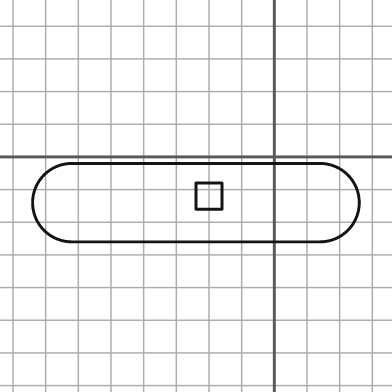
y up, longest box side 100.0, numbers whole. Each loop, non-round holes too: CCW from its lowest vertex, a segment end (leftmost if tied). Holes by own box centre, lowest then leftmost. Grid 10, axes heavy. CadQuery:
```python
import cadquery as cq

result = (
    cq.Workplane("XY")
    .moveTo(-62.0, -26.0)
    .lineTo(14.0, -26.0)
    .threePointArc((26.0, -14.0), (14.0, -2.0))
    .lineTo(-62.0, -2.0)
    .threePointArc((-74.0, -14.0), (-62.0, -26.0))
    .close()
    .moveTo(-24.0, -16.0)
    .lineTo(-16.0, -16.0)
    .lineTo(-16.0, -8.0)
    .lineTo(-24.0, -8.0)
    .close()
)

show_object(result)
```